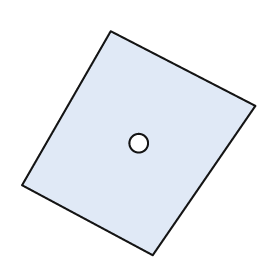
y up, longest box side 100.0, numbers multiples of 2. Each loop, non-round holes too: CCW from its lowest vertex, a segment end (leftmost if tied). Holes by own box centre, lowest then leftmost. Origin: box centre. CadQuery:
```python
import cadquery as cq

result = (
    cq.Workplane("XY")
    .moveTo(6.0, -48.0)
    .lineTo(50.0, 16.0)
    .lineTo(-12.0, 48.0)
    .lineTo(-50.0, -18.0)
    .close()
    .moveTo(0.0, 0.0)
    .circle(4.0)
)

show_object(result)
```